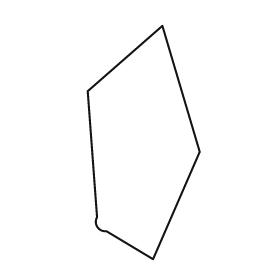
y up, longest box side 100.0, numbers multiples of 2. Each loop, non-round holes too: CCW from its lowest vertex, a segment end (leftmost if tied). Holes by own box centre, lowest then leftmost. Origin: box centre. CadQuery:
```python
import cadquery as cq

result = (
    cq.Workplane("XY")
    .moveTo(4.0, -50.0)
    .lineTo(24.0, -4.0)
    .lineTo(8.0, 50.0)
    .lineTo(-24.0, 22.0)
    .lineTo(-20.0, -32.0)
    .threePointArc((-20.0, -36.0), (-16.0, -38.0))
    .close()
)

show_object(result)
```